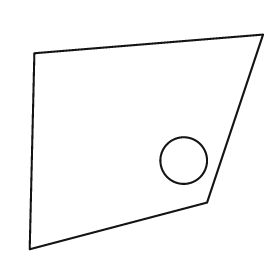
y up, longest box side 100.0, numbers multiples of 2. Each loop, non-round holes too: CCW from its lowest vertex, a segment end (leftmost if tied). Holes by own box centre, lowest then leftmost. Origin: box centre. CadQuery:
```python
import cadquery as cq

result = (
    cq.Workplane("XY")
    .moveTo(-50.0, -46.0)
    .lineTo(26.0, -26.0)
    .lineTo(50.0, 46.0)
    .lineTo(-48.0, 38.0)
    .close()
    .moveTo(16.0, -8.0)
    .circle(10.0)
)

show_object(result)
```